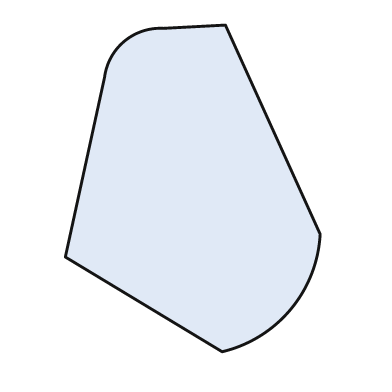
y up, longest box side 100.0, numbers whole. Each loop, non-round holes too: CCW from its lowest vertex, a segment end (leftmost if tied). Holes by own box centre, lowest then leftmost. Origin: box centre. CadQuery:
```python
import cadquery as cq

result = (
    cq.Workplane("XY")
    .moveTo(9.0, -50.0)
    .threePointArc((30.0, -37.0), (39.0, -14.0))
    .lineTo(10.0, 50.0)
    .lineTo(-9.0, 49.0)
    .threePointArc((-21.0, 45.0), (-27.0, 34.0))
    .lineTo(-39.0, -21.0)
    .close()
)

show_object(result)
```